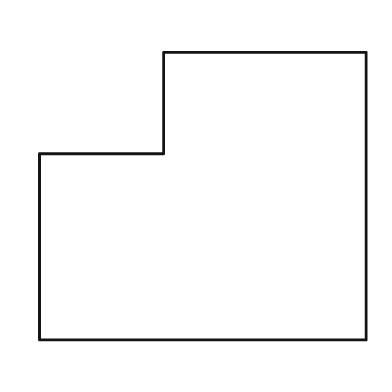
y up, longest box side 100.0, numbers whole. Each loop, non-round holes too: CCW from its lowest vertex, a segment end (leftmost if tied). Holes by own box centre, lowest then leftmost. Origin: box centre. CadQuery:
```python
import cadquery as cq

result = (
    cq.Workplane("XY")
    .moveTo(-50.0, -44.0)
    .lineTo(50.0, -44.0)
    .lineTo(50.0, 44.0)
    .lineTo(-12.0, 44.0)
    .lineTo(-12.0, 13.0)
    .lineTo(-50.0, 13.0)
    .close()
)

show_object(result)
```